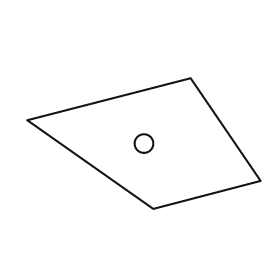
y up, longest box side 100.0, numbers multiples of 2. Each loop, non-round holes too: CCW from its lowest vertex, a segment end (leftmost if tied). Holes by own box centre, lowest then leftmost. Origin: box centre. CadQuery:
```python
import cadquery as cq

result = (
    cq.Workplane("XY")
    .moveTo(4.0, -28.0)
    .lineTo(50.0, -16.0)
    .lineTo(20.0, 28.0)
    .lineTo(-50.0, 10.0)
    .close()
    .moveTo(0.0, 0.0)
    .circle(4.0)
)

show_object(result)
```